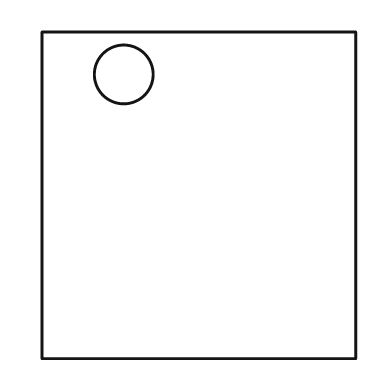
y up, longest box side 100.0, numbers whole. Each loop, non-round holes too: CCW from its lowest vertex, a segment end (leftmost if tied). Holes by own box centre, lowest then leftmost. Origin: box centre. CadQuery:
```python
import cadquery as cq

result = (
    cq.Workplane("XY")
    .moveTo(-48.0, -50.0)
    .lineTo(48.0, -50.0)
    .lineTo(48.0, 50.0)
    .lineTo(-48.0, 50.0)
    .close()
    .moveTo(-23.0, 37.0)
    .circle(9.0)
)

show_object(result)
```